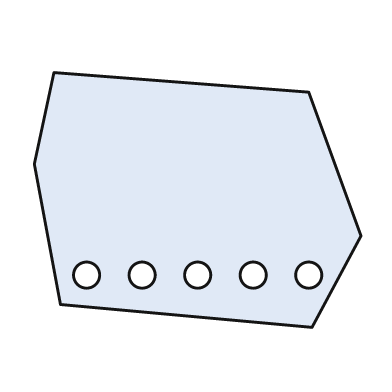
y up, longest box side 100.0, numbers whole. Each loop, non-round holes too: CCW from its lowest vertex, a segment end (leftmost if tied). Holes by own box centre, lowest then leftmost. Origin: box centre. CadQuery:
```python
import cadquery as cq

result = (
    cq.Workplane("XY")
    .moveTo(35.0, -39.0)
    .lineTo(50.0, -11.0)
    .lineTo(34.0, 33.0)
    .lineTo(-44.0, 39.0)
    .lineTo(-50.0, 11.0)
    .lineTo(-42.0, -32.0)
    .close()
    .moveTo(-34.0, -23.0)
    .circle(4.0)
    .moveTo(-17.0, -23.0)
    .circle(4.0)
    .moveTo(0.0, -23.0)
    .circle(4.0)
    .moveTo(17.0, -23.0)
    .circle(4.0)
    .moveTo(34.0, -23.0)
    .circle(4.0)
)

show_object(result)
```